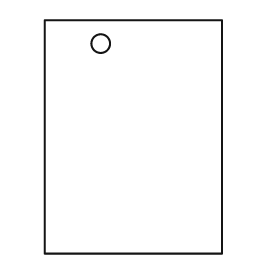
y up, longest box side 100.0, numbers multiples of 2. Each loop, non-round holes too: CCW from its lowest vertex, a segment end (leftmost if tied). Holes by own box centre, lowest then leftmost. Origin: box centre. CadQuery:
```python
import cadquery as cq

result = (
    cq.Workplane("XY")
    .moveTo(-38.0, -50.0)
    .lineTo(38.0, -50.0)
    .lineTo(38.0, 50.0)
    .lineTo(-38.0, 50.0)
    .close()
    .moveTo(-14.0, 40.0)
    .circle(4.0)
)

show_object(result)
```